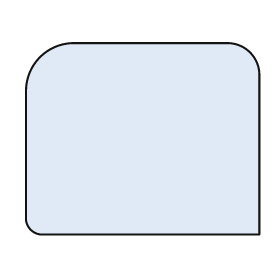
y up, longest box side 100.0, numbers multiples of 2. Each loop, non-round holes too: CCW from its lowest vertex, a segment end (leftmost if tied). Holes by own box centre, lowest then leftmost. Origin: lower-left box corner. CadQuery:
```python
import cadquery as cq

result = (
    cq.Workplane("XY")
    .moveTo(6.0, 0.0)
    .lineTo(100.0, 0.0)
    .lineTo(100.0, 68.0)
    .threePointArc((96.0, 78.0), (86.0, 82.0))
    .lineTo(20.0, 82.0)
    .threePointArc((6.0, 76.0), (0.0, 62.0))
    .lineTo(0.0, 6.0)
    .threePointArc((2.0, 2.0), (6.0, 0.0))
    .close()
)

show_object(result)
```